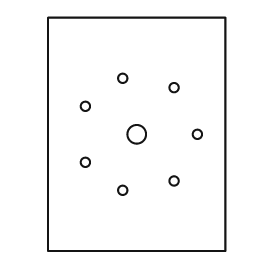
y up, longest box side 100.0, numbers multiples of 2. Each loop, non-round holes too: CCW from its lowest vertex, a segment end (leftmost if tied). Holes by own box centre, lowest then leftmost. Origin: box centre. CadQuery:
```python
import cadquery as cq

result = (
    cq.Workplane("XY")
    .moveTo(-38.0, -50.0)
    .lineTo(38.0, -50.0)
    .lineTo(38.0, 50.0)
    .lineTo(-38.0, 50.0)
    .close()
    .moveTo(-6.0, -24.0)
    .circle(2.0)
    .moveTo(16.0, -20.0)
    .circle(2.0)
    .moveTo(-22.0, -12.0)
    .circle(2.0)
    .moveTo(0.0, 0.0)
    .circle(4.0)
    .moveTo(26.0, 0.0)
    .circle(2.0)
    .moveTo(-22.0, 12.0)
    .circle(2.0)
    .moveTo(16.0, 20.0)
    .circle(2.0)
    .moveTo(-6.0, 24.0)
    .circle(2.0)
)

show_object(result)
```